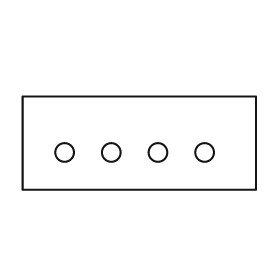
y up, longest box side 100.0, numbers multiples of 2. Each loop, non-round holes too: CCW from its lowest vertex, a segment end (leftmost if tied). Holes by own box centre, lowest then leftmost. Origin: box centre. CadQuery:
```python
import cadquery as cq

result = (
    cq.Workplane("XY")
    .moveTo(-50.0, -20.0)
    .lineTo(50.0, -20.0)
    .lineTo(50.0, 20.0)
    .lineTo(-50.0, 20.0)
    .close()
    .moveTo(-32.0, -4.0)
    .circle(4.0)
    .moveTo(-12.0, -4.0)
    .circle(4.0)
    .moveTo(8.0, -4.0)
    .circle(4.0)
    .moveTo(28.0, -4.0)
    .circle(4.0)
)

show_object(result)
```